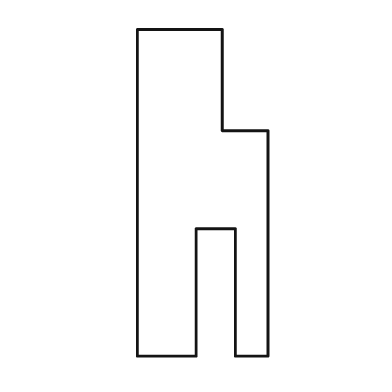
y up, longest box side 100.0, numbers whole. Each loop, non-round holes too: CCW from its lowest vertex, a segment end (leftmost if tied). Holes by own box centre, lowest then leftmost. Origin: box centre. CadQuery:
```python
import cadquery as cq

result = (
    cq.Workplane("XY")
    .moveTo(-20.0, -50.0)
    .lineTo(-2.0, -50.0)
    .lineTo(-2.0, -11.0)
    .lineTo(10.0, -11.0)
    .lineTo(10.0, -50.0)
    .lineTo(20.0, -50.0)
    .lineTo(20.0, 19.0)
    .lineTo(6.0, 19.0)
    .lineTo(6.0, 50.0)
    .lineTo(-20.0, 50.0)
    .close()
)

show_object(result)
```